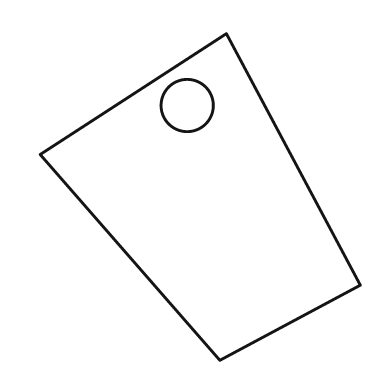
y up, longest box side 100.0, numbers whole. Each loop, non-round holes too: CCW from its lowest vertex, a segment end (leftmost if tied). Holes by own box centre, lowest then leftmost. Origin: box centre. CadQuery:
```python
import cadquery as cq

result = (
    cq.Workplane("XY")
    .moveTo(6.0, -50.0)
    .lineTo(49.0, -27.0)
    .lineTo(8.0, 50.0)
    .lineTo(-49.0, 13.0)
    .close()
    .moveTo(-4.0, 28.0)
    .circle(8.0)
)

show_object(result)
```